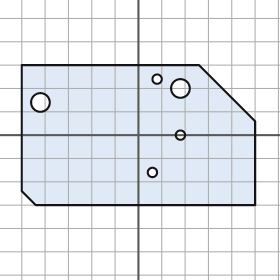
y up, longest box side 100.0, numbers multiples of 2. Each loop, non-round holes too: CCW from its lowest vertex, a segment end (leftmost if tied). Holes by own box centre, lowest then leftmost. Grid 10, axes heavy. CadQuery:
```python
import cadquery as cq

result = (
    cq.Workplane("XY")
    .moveTo(-44.0, -30.0)
    .lineTo(50.0, -30.0)
    .lineTo(50.0, 6.0)
    .lineTo(26.0, 30.0)
    .lineTo(-50.0, 30.0)
    .lineTo(-50.0, -24.0)
    .close()
    .moveTo(6.0, -16.0)
    .circle(2.0)
    .moveTo(18.0, 0.0)
    .circle(2.0)
    .moveTo(-42.0, 14.0)
    .circle(4.0)
    .moveTo(18.0, 20.0)
    .circle(4.0)
    .moveTo(8.0, 24.0)
    .circle(2.0)
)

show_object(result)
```